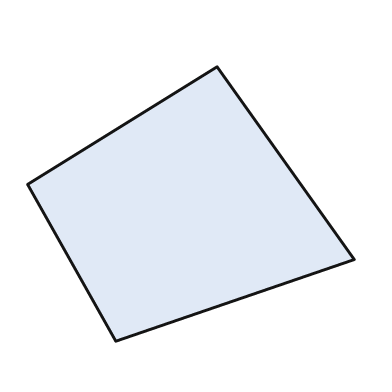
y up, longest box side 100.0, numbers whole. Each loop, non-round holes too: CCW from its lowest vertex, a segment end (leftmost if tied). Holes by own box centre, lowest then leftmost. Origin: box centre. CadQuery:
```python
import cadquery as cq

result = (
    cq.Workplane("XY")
    .moveTo(-23.0, -42.0)
    .lineTo(50.0, -17.0)
    .lineTo(8.0, 42.0)
    .lineTo(-50.0, 6.0)
    .close()
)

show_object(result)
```